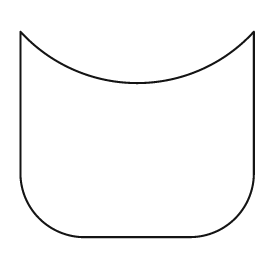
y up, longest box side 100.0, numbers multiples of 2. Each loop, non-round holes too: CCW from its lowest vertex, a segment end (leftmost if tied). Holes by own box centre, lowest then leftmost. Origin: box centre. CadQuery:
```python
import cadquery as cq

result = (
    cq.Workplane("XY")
    .moveTo(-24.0, -44.0)
    .lineTo(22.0, -44.0)
    .threePointArc((42.0, -36.0), (50.0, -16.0))
    .lineTo(50.0, 44.0)
    .threePointArc((0.0, 22.0), (-50.0, 44.0))
    .lineTo(-50.0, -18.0)
    .threePointArc((-42.0, -36.0), (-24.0, -44.0))
    .close()
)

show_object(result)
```